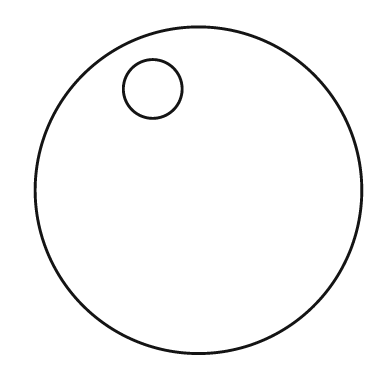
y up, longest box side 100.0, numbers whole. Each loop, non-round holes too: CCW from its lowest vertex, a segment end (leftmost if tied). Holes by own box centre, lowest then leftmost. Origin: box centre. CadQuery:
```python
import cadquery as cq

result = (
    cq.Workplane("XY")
    .moveTo(0.0, 0.0)
    .circle(50.0)
    .moveTo(-14.0, 31.0)
    .circle(9.0)
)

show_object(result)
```